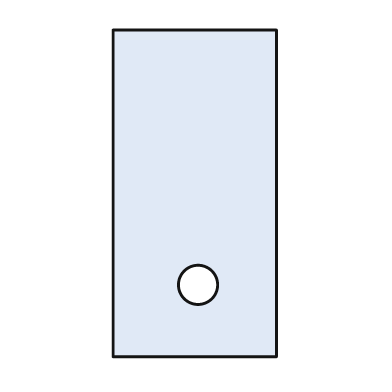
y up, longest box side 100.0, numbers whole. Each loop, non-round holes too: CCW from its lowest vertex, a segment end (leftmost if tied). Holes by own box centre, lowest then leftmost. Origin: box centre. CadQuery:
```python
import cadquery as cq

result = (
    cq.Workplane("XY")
    .moveTo(-25.0, -50.0)
    .lineTo(25.0, -50.0)
    .lineTo(25.0, 50.0)
    .lineTo(-25.0, 50.0)
    .close()
    .moveTo(1.0, -28.0)
    .circle(6.0)
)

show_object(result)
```